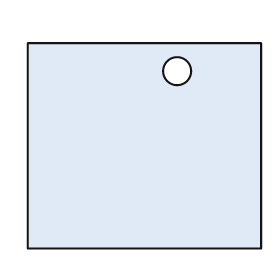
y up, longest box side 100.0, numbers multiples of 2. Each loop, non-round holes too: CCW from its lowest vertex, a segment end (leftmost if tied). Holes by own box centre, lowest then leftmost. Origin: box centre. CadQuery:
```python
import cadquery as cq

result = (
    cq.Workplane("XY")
    .moveTo(-50.0, -44.0)
    .lineTo(50.0, -44.0)
    .lineTo(50.0, 44.0)
    .lineTo(-50.0, 44.0)
    .close()
    .moveTo(14.0, 32.0)
    .circle(6.0)
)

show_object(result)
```